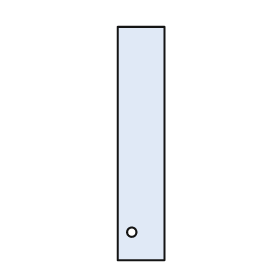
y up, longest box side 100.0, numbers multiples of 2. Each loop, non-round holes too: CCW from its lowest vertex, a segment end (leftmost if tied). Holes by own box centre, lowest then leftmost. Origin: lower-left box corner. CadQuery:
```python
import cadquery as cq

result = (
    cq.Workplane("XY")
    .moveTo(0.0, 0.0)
    .lineTo(20.0, 0.0)
    .lineTo(20.0, 100.0)
    .lineTo(0.0, 100.0)
    .close()
    .moveTo(6.0, 12.0)
    .circle(2.0)
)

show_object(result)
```